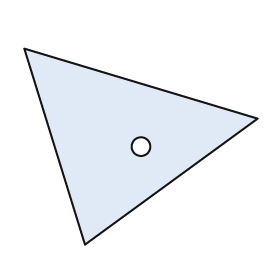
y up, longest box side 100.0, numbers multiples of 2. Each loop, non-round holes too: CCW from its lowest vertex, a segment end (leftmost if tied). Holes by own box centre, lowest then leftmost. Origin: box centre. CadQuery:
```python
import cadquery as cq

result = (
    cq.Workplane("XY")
    .moveTo(-24.0, -42.0)
    .lineTo(50.0, 12.0)
    .lineTo(-50.0, 42.0)
    .close()
    .moveTo(0.0, 0.0)
    .circle(4.0)
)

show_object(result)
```